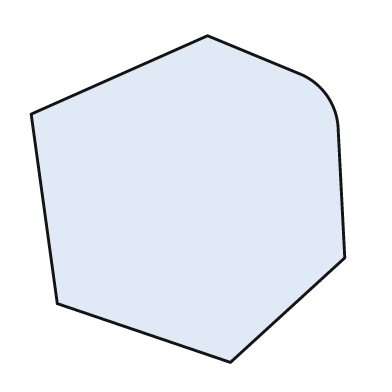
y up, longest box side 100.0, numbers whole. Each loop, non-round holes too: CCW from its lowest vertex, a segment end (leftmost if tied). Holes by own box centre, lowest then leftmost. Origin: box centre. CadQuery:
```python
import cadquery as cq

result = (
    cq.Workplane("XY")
    .moveTo(13.0, -50.0)
    .lineTo(48.0, -18.0)
    .lineTo(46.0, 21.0)
    .threePointArc((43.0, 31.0), (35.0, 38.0))
    .lineTo(6.0, 50.0)
    .lineTo(-48.0, 26.0)
    .lineTo(-40.0, -32.0)
    .close()
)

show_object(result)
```